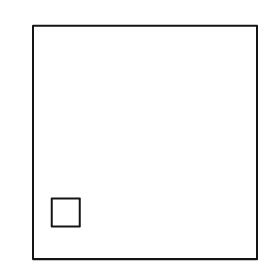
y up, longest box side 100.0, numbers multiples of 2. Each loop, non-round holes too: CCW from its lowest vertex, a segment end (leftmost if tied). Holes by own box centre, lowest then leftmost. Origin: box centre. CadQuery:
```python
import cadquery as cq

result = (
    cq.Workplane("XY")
    .moveTo(-48.0, -50.0)
    .lineTo(48.0, -50.0)
    .lineTo(48.0, 50.0)
    .lineTo(-48.0, 50.0)
    .close()
    .moveTo(-40.0, -36.0)
    .lineTo(-28.0, -36.0)
    .lineTo(-28.0, -24.0)
    .lineTo(-40.0, -24.0)
    .close()
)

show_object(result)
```